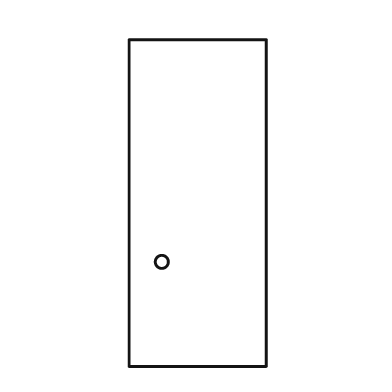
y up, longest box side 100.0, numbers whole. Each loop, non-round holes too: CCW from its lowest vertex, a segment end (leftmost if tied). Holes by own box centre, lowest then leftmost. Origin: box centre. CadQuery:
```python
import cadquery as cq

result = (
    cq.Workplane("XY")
    .moveTo(-21.0, -50.0)
    .lineTo(21.0, -50.0)
    .lineTo(21.0, 50.0)
    .lineTo(-21.0, 50.0)
    .close()
    .moveTo(-11.0, -18.0)
    .circle(2.0)
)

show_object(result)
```